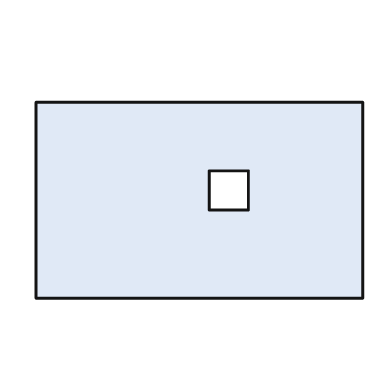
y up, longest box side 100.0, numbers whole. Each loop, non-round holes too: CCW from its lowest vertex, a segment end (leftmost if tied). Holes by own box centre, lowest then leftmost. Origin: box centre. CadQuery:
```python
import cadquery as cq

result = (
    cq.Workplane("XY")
    .moveTo(-50.0, -30.0)
    .lineTo(50.0, -30.0)
    .lineTo(50.0, 30.0)
    .lineTo(-50.0, 30.0)
    .close()
    .moveTo(3.0, -3.0)
    .lineTo(15.0, -3.0)
    .lineTo(15.0, 9.0)
    .lineTo(3.0, 9.0)
    .close()
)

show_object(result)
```